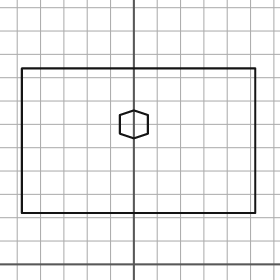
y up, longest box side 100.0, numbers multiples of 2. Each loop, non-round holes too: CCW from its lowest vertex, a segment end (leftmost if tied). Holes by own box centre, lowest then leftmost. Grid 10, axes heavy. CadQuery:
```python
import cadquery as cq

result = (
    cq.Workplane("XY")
    .moveTo(-48.0, 22.0)
    .lineTo(52.0, 22.0)
    .lineTo(52.0, 84.0)
    .lineTo(-48.0, 84.0)
    .close()
    .moveTo(0.0, 54.0)
    .lineTo(6.0, 56.0)
    .lineTo(6.0, 64.0)
    .lineTo(0.0, 66.0)
    .lineTo(-6.0, 64.0)
    .lineTo(-6.0, 56.0)
    .close()
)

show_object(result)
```